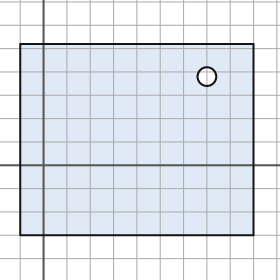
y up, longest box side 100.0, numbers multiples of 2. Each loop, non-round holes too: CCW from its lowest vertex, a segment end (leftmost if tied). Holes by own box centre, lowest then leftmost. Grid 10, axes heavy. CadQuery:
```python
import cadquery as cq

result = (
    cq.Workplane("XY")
    .moveTo(-10.0, -30.0)
    .lineTo(90.0, -30.0)
    .lineTo(90.0, 52.0)
    .lineTo(-10.0, 52.0)
    .close()
    .moveTo(70.0, 38.0)
    .circle(4.0)
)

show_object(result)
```